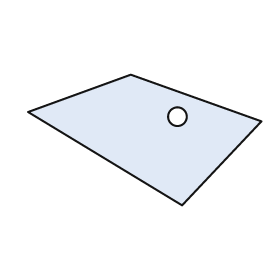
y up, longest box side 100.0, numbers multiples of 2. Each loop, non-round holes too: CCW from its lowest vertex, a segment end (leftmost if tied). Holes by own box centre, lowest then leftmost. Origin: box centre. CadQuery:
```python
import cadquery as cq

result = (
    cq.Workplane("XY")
    .moveTo(16.0, -28.0)
    .lineTo(50.0, 8.0)
    .lineTo(-6.0, 28.0)
    .lineTo(-50.0, 12.0)
    .close()
    .moveTo(14.0, 10.0)
    .circle(4.0)
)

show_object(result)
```